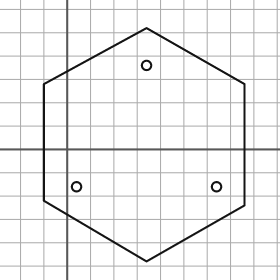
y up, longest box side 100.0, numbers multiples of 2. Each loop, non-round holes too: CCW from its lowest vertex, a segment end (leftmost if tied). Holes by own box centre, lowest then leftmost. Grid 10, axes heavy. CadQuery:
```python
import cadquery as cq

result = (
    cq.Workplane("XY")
    .moveTo(34.0, -48.0)
    .lineTo(76.0, -24.0)
    .lineTo(76.0, 28.0)
    .lineTo(34.0, 52.0)
    .lineTo(-10.0, 28.0)
    .lineTo(-10.0, -22.0)
    .close()
    .moveTo(4.0, -16.0)
    .circle(2.0)
    .moveTo(64.0, -16.0)
    .circle(2.0)
    .moveTo(34.0, 36.0)
    .circle(2.0)
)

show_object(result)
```